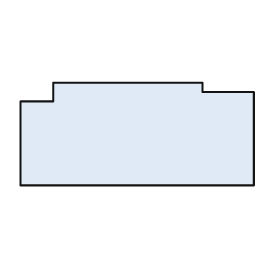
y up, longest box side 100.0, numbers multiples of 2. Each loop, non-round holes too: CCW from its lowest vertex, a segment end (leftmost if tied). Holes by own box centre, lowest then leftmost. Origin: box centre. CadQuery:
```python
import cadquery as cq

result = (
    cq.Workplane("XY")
    .moveTo(-50.0, -22.0)
    .lineTo(50.0, -22.0)
    .lineTo(50.0, 18.0)
    .lineTo(28.0, 18.0)
    .lineTo(28.0, 22.0)
    .lineTo(-36.0, 22.0)
    .lineTo(-36.0, 14.0)
    .lineTo(-50.0, 14.0)
    .close()
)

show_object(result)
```